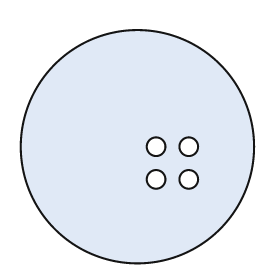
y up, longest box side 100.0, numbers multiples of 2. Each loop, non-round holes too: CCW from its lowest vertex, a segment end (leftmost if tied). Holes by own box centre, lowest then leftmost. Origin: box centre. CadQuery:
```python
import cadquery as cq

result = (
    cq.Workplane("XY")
    .moveTo(0.0, 0.0)
    .circle(50.0)
    .moveTo(8.0, -14.0)
    .circle(4.0)
    .moveTo(22.0, -14.0)
    .circle(4.0)
    .moveTo(8.0, 0.0)
    .circle(4.0)
    .moveTo(22.0, 0.0)
    .circle(4.0)
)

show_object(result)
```